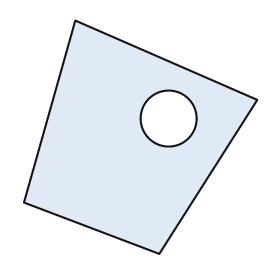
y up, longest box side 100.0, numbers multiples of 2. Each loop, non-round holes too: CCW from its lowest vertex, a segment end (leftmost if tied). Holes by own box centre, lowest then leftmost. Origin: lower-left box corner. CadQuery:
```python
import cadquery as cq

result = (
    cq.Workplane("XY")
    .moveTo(58.0, 0.0)
    .lineTo(100.0, 66.0)
    .lineTo(22.0, 100.0)
    .lineTo(0.0, 22.0)
    .close()
    .moveTo(62.0, 58.0)
    .circle(12.0)
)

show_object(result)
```